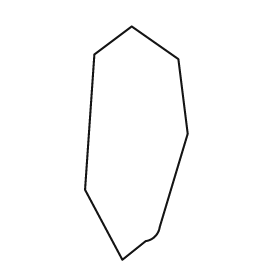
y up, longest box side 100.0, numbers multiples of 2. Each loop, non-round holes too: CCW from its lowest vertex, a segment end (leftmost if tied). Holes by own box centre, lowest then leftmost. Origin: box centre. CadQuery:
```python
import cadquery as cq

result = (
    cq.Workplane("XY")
    .moveTo(-6.0, -50.0)
    .lineTo(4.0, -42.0)
    .threePointArc((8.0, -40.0), (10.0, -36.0))
    .lineTo(22.0, 4.0)
    .lineTo(18.0, 36.0)
    .lineTo(-2.0, 50.0)
    .lineTo(-18.0, 38.0)
    .lineTo(-22.0, -20.0)
    .close()
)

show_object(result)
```